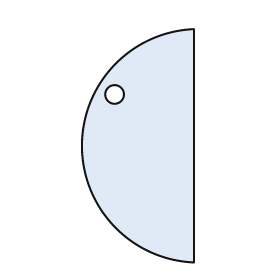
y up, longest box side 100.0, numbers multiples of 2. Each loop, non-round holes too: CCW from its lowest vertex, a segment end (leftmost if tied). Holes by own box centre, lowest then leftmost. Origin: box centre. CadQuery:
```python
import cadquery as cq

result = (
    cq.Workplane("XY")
    .moveTo(24.0, -50.0)
    .lineTo(24.0, 50.0)
    .threePointArc((-24.0, 0.0), (24.0, -50.0))
    .close()
    .moveTo(-10.0, 22.0)
    .circle(4.0)
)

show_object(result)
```